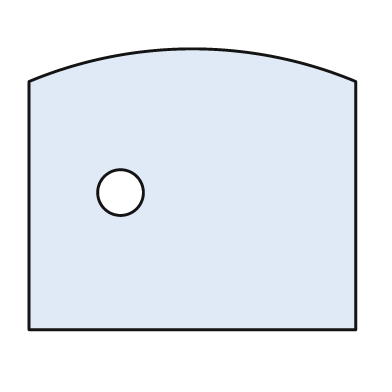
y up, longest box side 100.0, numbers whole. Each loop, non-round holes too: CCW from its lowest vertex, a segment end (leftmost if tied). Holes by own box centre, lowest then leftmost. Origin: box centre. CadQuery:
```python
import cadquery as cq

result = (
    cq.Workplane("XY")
    .moveTo(-50.0, -43.0)
    .lineTo(50.0, -43.0)
    .lineTo(50.0, 33.0)
    .threePointArc((0.0, 43.0), (-50.0, 33.0))
    .close()
    .moveTo(-22.0, -1.0)
    .circle(7.0)
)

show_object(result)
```